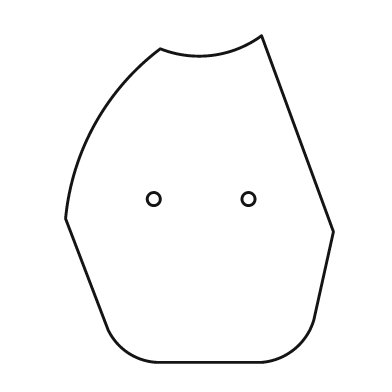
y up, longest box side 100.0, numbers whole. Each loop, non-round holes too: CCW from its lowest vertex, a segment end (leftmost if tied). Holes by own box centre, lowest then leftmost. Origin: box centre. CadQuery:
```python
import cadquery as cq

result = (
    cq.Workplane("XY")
    .moveTo(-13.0, -50.0)
    .lineTo(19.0, -50.0)
    .threePointArc((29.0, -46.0), (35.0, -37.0))
    .lineTo(41.0, -10.0)
    .lineTo(19.0, 50.0)
    .threePointArc((4.0, 44.0), (-12.0, 46.0))
    .threePointArc((-32.0, 23.0), (-41.0, -6.0))
    .lineTo(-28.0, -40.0)
    .threePointArc((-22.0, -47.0), (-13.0, -50.0))
    .close()
    .moveTo(-14.0, 0.0)
    .circle(2.0)
    .moveTo(15.0, 0.0)
    .circle(2.0)
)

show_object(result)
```